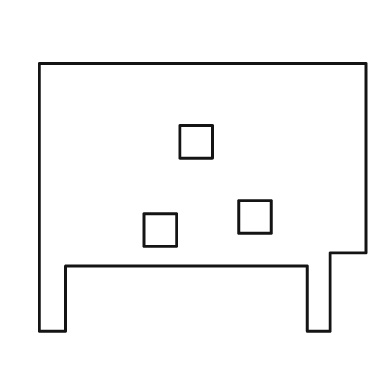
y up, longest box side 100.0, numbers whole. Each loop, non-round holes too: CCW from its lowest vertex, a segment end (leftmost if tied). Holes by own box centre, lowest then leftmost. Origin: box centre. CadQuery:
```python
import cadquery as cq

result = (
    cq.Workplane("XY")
    .moveTo(-50.0, -41.0)
    .lineTo(-42.0, -41.0)
    .lineTo(-42.0, -21.0)
    .lineTo(32.0, -21.0)
    .lineTo(32.0, -41.0)
    .lineTo(39.0, -41.0)
    .lineTo(39.0, -17.0)
    .lineTo(50.0, -17.0)
    .lineTo(50.0, 41.0)
    .lineTo(-50.0, 41.0)
    .close()
    .moveTo(-18.0, -15.0)
    .lineTo(-8.0, -15.0)
    .lineTo(-8.0, -5.0)
    .lineTo(-18.0, -5.0)
    .close()
    .moveTo(11.0, -11.0)
    .lineTo(21.0, -11.0)
    .lineTo(21.0, -1.0)
    .lineTo(11.0, -1.0)
    .close()
    .moveTo(-7.0, 12.0)
    .lineTo(3.0, 12.0)
    .lineTo(3.0, 22.0)
    .lineTo(-7.0, 22.0)
    .close()
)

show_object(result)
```